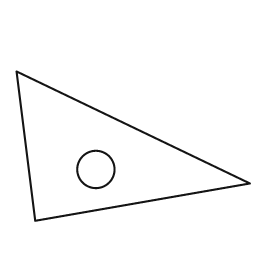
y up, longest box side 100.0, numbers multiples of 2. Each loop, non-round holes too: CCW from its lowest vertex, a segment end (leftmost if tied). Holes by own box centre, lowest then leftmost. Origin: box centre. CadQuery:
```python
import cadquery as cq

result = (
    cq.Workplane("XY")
    .moveTo(-42.0, -32.0)
    .lineTo(50.0, -16.0)
    .lineTo(-50.0, 32.0)
    .close()
    .moveTo(-16.0, -10.0)
    .circle(8.0)
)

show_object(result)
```